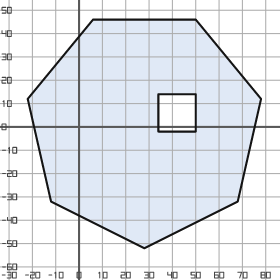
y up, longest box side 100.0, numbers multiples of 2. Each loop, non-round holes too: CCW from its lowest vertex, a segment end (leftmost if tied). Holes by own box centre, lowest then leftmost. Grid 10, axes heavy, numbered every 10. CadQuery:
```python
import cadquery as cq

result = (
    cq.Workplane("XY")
    .moveTo(28.0, -52.0)
    .lineTo(68.0, -32.0)
    .lineTo(78.0, 12.0)
    .lineTo(50.0, 46.0)
    .lineTo(6.0, 46.0)
    .lineTo(-22.0, 12.0)
    .lineTo(-12.0, -32.0)
    .close()
    .moveTo(34.0, -2.0)
    .lineTo(50.0, -2.0)
    .lineTo(50.0, 14.0)
    .lineTo(34.0, 14.0)
    .close()
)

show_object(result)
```